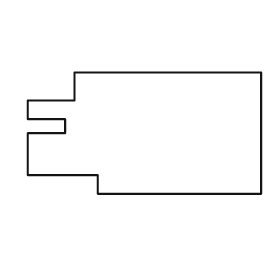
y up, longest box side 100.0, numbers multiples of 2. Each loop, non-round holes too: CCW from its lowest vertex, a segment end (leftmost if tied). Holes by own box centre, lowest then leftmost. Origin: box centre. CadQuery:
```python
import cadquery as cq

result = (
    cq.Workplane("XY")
    .moveTo(-20.0, -26.0)
    .lineTo(50.0, -26.0)
    .lineTo(50.0, 26.0)
    .lineTo(-30.0, 26.0)
    .lineTo(-30.0, 14.0)
    .lineTo(-50.0, 14.0)
    .lineTo(-50.0, 6.0)
    .lineTo(-34.0, 6.0)
    .lineTo(-34.0, 0.0)
    .lineTo(-50.0, 0.0)
    .lineTo(-50.0, -18.0)
    .lineTo(-20.0, -18.0)
    .close()
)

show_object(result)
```